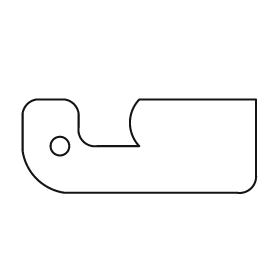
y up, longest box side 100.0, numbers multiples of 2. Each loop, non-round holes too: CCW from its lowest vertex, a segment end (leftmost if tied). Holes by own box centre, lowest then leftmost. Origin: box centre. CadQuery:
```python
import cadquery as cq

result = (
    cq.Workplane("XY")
    .moveTo(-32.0, -20.0)
    .lineTo(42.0, -20.0)
    .threePointArc((48.0, -18.0), (50.0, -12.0))
    .lineTo(50.0, 20.0)
    .lineTo(0.0, 20.0)
    .threePointArc((-4.0, 10.0), (0.0, 0.0))
    .lineTo(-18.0, 0.0)
    .threePointArc((-24.0, 2.0), (-26.0, 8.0))
    .lineTo(-26.0, 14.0)
    .threePointArc((-28.0, 18.0), (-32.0, 20.0))
    .lineTo(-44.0, 20.0)
    .threePointArc((-48.0, 18.0), (-50.0, 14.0))
    .lineTo(-50.0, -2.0)
    .threePointArc((-44.0, -14.0), (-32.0, -20.0))
    .close()
    .moveTo(-34.0, 0.0)
    .circle(4.0)
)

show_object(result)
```